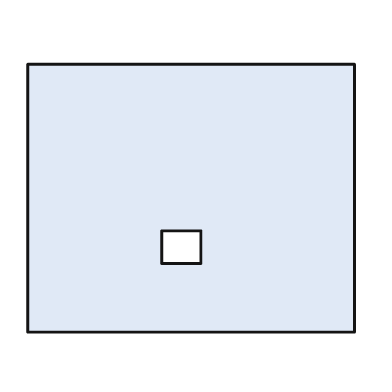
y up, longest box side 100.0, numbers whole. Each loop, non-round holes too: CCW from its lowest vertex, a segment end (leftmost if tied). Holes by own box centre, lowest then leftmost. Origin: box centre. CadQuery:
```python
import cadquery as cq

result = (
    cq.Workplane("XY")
    .moveTo(-50.0, -41.0)
    .lineTo(50.0, -41.0)
    .lineTo(50.0, 41.0)
    .lineTo(-50.0, 41.0)
    .close()
    .moveTo(-9.0, -20.0)
    .lineTo(3.0, -20.0)
    .lineTo(3.0, -10.0)
    .lineTo(-9.0, -10.0)
    .close()
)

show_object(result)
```